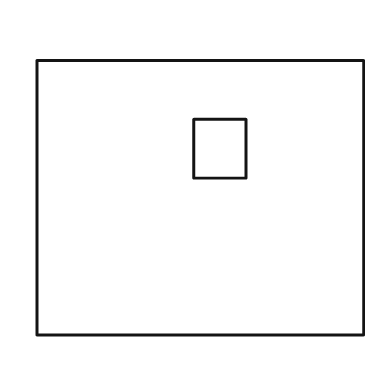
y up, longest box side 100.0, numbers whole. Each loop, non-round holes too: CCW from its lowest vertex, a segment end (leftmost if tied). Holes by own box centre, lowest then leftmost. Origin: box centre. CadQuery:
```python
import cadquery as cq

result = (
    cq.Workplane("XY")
    .moveTo(-50.0, -42.0)
    .lineTo(50.0, -42.0)
    .lineTo(50.0, 42.0)
    .lineTo(-50.0, 42.0)
    .close()
    .moveTo(-2.0, 6.0)
    .lineTo(14.0, 6.0)
    .lineTo(14.0, 24.0)
    .lineTo(-2.0, 24.0)
    .close()
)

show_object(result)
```